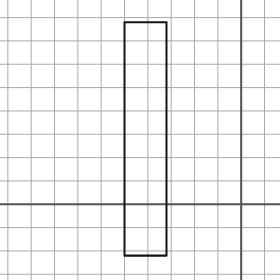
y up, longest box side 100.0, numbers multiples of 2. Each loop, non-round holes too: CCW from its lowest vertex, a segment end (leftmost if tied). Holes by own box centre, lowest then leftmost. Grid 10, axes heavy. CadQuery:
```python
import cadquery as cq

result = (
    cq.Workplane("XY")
    .moveTo(-50.0, -22.0)
    .lineTo(-32.0, -22.0)
    .lineTo(-32.0, 78.0)
    .lineTo(-50.0, 78.0)
    .close()
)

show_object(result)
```